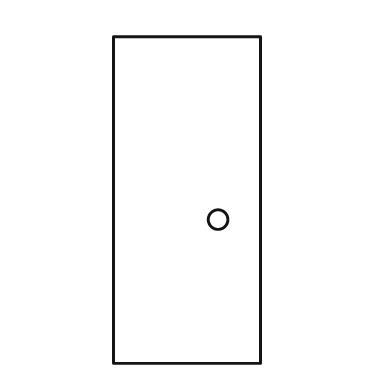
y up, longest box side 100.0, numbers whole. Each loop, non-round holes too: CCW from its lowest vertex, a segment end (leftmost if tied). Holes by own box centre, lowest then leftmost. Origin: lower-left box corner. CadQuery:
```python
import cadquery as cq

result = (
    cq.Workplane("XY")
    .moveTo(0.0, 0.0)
    .lineTo(45.0, 0.0)
    .lineTo(45.0, 100.0)
    .lineTo(0.0, 100.0)
    .close()
    .moveTo(32.0, 44.0)
    .circle(3.0)
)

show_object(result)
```